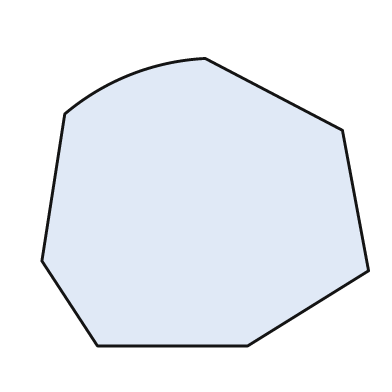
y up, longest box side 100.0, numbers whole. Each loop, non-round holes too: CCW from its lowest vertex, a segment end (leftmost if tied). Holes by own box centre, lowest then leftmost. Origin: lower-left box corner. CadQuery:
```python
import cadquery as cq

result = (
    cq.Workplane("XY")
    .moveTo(17.0, 0.0)
    .lineTo(63.0, 0.0)
    .lineTo(100.0, 23.0)
    .lineTo(92.0, 66.0)
    .lineTo(50.0, 88.0)
    .threePointArc((27.0, 83.0), (7.0, 71.0))
    .lineTo(0.0, 26.0)
    .close()
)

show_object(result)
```